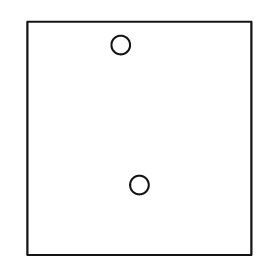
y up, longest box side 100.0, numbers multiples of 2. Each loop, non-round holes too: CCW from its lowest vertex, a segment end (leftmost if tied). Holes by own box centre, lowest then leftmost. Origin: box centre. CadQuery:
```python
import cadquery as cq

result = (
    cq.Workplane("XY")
    .moveTo(-48.0, -50.0)
    .lineTo(48.0, -50.0)
    .lineTo(48.0, 50.0)
    .lineTo(-48.0, 50.0)
    .close()
    .moveTo(0.0, -20.0)
    .circle(4.0)
    .moveTo(-8.0, 40.0)
    .circle(4.0)
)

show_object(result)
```